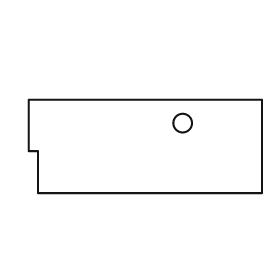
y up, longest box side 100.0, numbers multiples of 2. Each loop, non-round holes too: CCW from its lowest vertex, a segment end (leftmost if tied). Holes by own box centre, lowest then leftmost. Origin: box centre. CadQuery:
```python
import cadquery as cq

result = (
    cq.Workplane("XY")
    .moveTo(-46.0, -20.0)
    .lineTo(50.0, -20.0)
    .lineTo(50.0, 20.0)
    .lineTo(-50.0, 20.0)
    .lineTo(-50.0, -2.0)
    .lineTo(-46.0, -2.0)
    .close()
    .moveTo(16.0, 10.0)
    .circle(4.0)
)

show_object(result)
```